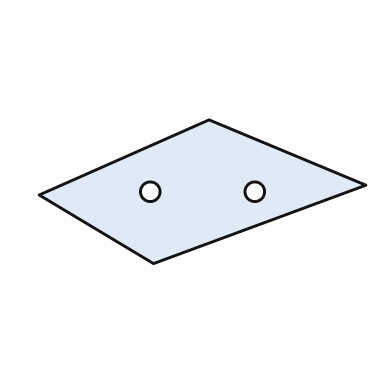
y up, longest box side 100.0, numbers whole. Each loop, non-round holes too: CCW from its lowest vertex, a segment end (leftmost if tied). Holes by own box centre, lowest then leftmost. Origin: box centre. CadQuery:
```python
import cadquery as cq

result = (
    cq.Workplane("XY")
    .moveTo(-15.0, -22.0)
    .lineTo(50.0, 2.0)
    .lineTo(2.0, 22.0)
    .lineTo(-50.0, -1.0)
    .close()
    .moveTo(-16.0, 0.0)
    .circle(3.0)
    .moveTo(16.0, 0.0)
    .circle(3.0)
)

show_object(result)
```